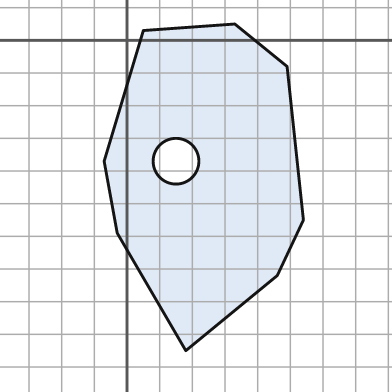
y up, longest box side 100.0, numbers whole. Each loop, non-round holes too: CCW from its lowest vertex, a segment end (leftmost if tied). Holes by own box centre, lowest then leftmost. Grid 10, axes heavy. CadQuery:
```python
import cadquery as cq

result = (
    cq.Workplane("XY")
    .moveTo(18.0, -95.0)
    .lineTo(46.0, -72.0)
    .lineTo(54.0, -55.0)
    .lineTo(49.0, -8.0)
    .lineTo(33.0, 5.0)
    .lineTo(5.0, 3.0)
    .lineTo(-7.0, -37.0)
    .lineTo(-3.0, -59.0)
    .close()
    .moveTo(15.0, -37.0)
    .circle(7.0)
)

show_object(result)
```